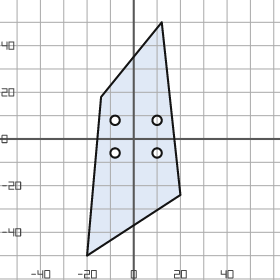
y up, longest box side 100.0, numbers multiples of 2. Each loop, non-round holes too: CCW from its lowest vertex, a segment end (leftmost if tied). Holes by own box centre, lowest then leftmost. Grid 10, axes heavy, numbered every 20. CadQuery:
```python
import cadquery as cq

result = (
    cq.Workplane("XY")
    .moveTo(-20.0, -50.0)
    .lineTo(20.0, -24.0)
    .lineTo(12.0, 50.0)
    .lineTo(-14.0, 18.0)
    .close()
    .moveTo(-8.0, -6.0)
    .circle(2.0)
    .moveTo(10.0, -6.0)
    .circle(2.0)
    .moveTo(-8.0, 8.0)
    .circle(2.0)
    .moveTo(10.0, 8.0)
    .circle(2.0)
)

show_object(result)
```